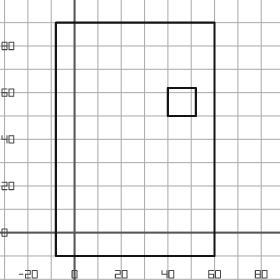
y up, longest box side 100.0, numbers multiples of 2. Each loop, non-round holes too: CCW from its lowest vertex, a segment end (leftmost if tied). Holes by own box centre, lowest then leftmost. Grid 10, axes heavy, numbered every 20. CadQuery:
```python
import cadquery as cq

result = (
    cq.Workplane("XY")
    .moveTo(-8.0, -10.0)
    .lineTo(60.0, -10.0)
    .lineTo(60.0, 90.0)
    .lineTo(-8.0, 90.0)
    .close()
    .moveTo(40.0, 50.0)
    .lineTo(52.0, 50.0)
    .lineTo(52.0, 62.0)
    .lineTo(40.0, 62.0)
    .close()
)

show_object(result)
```